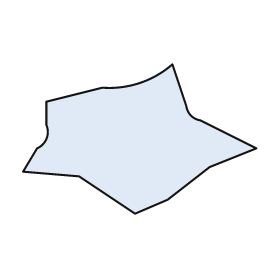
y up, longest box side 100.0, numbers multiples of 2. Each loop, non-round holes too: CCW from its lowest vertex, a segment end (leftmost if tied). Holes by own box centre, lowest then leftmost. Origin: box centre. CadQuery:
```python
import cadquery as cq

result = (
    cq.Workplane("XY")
    .moveTo(-2.0, -32.0)
    .lineTo(12.0, -26.0)
    .lineTo(30.0, -12.0)
    .lineTo(50.0, -4.0)
    .lineTo(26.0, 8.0)
    .threePointArc((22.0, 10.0), (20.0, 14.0))
    .lineTo(14.0, 32.0)
    .threePointArc((0.0, 24.0), (-16.0, 22.0))
    .lineTo(-40.0, 16.0)
    .lineTo(-40.0, 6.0)
    .threePointArc((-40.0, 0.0), (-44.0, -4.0))
    .lineTo(-50.0, -14.0)
    .lineTo(-26.0, -16.0)
    .close()
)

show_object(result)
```